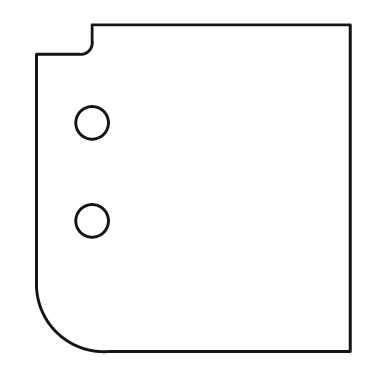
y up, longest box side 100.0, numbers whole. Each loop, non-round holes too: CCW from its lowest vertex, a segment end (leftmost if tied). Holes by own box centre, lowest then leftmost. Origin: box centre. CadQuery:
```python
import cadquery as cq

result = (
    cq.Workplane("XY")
    .moveTo(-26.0, -50.0)
    .lineTo(48.0, -50.0)
    .lineTo(48.0, 50.0)
    .lineTo(-31.0, 50.0)
    .lineTo(-31.0, 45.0)
    .threePointArc((-32.0, 42.0), (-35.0, 41.0))
    .lineTo(-48.0, 41.0)
    .lineTo(-48.0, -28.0)
    .threePointArc((-42.0, -44.0), (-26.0, -50.0))
    .close()
    .moveTo(-31.0, -10.0)
    .circle(5.0)
    .moveTo(-31.0, 20.0)
    .circle(5.0)
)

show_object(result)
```